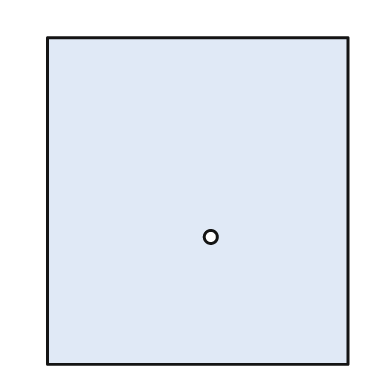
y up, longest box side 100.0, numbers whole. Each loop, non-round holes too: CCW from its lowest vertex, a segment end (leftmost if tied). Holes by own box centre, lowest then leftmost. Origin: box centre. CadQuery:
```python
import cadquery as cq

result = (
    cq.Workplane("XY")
    .moveTo(-46.0, -50.0)
    .lineTo(46.0, -50.0)
    .lineTo(46.0, 50.0)
    .lineTo(-46.0, 50.0)
    .close()
    .moveTo(4.0, -11.0)
    .circle(2.0)
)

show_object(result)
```